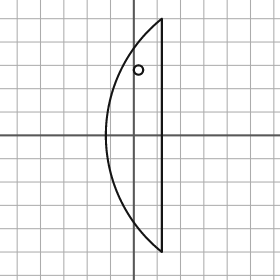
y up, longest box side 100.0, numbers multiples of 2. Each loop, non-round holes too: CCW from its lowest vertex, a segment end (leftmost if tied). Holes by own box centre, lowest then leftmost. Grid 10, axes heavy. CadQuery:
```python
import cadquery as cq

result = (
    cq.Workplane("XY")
    .moveTo(12.0, -50.0)
    .lineTo(12.0, 50.0)
    .threePointArc((-12.0, 0.0), (12.0, -50.0))
    .close()
    .moveTo(2.0, 28.0)
    .circle(2.0)
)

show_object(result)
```